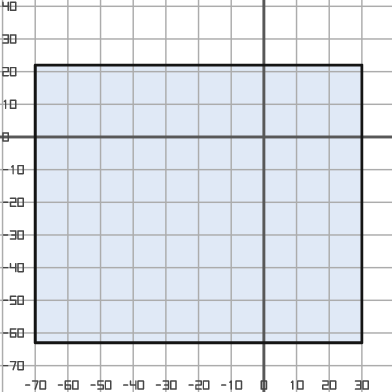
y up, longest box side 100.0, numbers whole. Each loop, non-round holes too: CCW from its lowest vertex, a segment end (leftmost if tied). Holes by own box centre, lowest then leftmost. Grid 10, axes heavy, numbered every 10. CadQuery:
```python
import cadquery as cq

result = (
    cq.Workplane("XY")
    .moveTo(-70.0, -63.0)
    .lineTo(30.0, -63.0)
    .lineTo(30.0, 22.0)
    .lineTo(-70.0, 22.0)
    .close()
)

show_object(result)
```